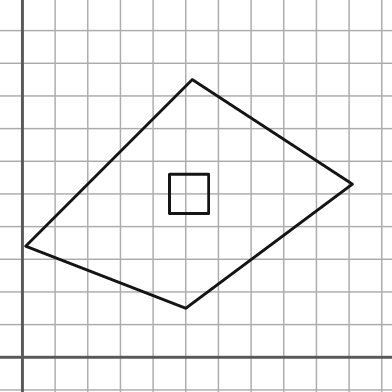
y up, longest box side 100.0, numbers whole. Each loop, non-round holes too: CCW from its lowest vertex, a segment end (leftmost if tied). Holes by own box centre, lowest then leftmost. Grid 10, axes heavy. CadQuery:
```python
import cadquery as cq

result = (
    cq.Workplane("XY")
    .moveTo(50.0, 15.0)
    .lineTo(101.0, 53.0)
    .lineTo(52.0, 85.0)
    .lineTo(1.0, 34.0)
    .close()
    .moveTo(45.0, 44.0)
    .lineTo(57.0, 44.0)
    .lineTo(57.0, 56.0)
    .lineTo(45.0, 56.0)
    .close()
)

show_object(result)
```